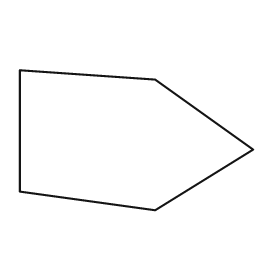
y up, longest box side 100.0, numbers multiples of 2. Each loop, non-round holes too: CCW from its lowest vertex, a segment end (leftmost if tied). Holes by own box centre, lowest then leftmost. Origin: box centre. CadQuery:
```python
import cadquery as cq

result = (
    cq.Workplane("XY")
    .moveTo(8.0, -30.0)
    .lineTo(50.0, -4.0)
    .lineTo(8.0, 26.0)
    .lineTo(-50.0, 30.0)
    .lineTo(-50.0, -22.0)
    .close()
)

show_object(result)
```